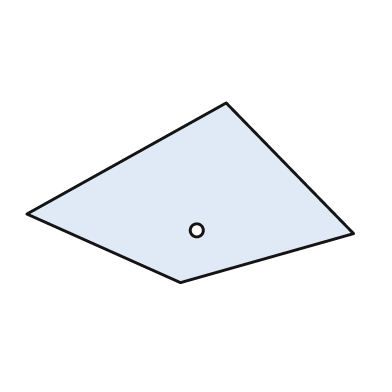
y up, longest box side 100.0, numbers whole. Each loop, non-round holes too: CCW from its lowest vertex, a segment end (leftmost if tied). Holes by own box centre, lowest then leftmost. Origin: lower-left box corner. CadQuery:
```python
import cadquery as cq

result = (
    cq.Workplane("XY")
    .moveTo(47.0, 0.0)
    .lineTo(100.0, 15.0)
    .lineTo(61.0, 55.0)
    .lineTo(0.0, 21.0)
    .close()
    .moveTo(52.0, 16.0)
    .circle(2.0)
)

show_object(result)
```